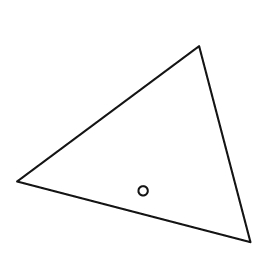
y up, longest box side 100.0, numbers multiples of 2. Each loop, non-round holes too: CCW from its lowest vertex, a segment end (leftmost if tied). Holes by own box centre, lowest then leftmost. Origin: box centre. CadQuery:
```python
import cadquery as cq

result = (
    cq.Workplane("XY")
    .moveTo(50.0, -42.0)
    .lineTo(28.0, 42.0)
    .lineTo(-50.0, -16.0)
    .close()
    .moveTo(4.0, -20.0)
    .circle(2.0)
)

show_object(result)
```